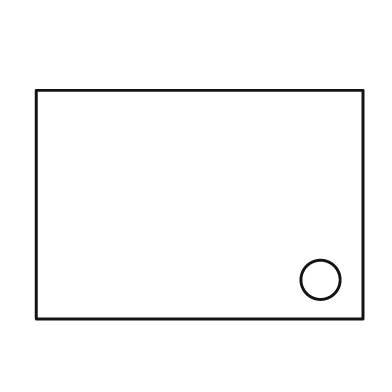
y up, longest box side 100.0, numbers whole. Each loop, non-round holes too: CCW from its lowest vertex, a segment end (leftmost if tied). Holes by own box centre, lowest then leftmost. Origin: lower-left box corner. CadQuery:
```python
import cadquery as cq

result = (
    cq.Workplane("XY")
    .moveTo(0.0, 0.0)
    .lineTo(100.0, 0.0)
    .lineTo(100.0, 70.0)
    .lineTo(0.0, 70.0)
    .close()
    .moveTo(87.0, 12.0)
    .circle(6.0)
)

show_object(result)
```